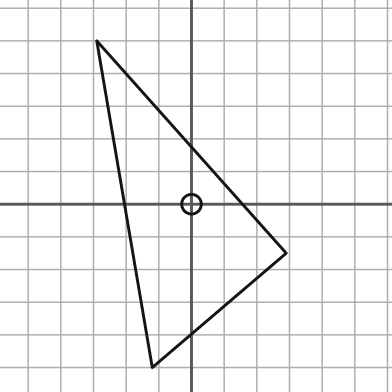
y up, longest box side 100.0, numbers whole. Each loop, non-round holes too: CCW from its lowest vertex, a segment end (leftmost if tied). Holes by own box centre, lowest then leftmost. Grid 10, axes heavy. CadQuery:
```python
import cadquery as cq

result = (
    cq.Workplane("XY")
    .moveTo(-12.0, -50.0)
    .lineTo(29.0, -15.0)
    .lineTo(-29.0, 50.0)
    .close()
    .moveTo(0.0, 0.0)
    .circle(3.0)
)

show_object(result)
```